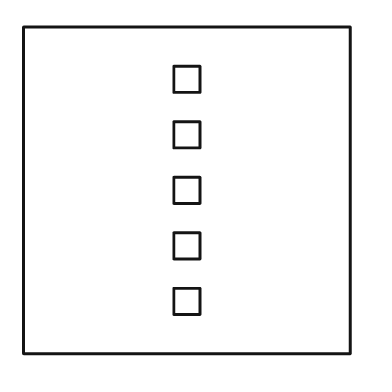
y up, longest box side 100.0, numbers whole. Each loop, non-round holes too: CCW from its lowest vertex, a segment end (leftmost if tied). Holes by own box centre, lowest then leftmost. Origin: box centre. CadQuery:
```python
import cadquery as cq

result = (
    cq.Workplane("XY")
    .moveTo(-50.0, -50.0)
    .lineTo(50.0, -50.0)
    .lineTo(50.0, 50.0)
    .lineTo(-50.0, 50.0)
    .close()
    .moveTo(-4.0, -38.0)
    .lineTo(4.0, -38.0)
    .lineTo(4.0, -30.0)
    .lineTo(-4.0, -30.0)
    .close()
    .moveTo(-4.0, -21.0)
    .lineTo(4.0, -21.0)
    .lineTo(4.0, -13.0)
    .lineTo(-4.0, -13.0)
    .close()
    .moveTo(-4.0, -4.0)
    .lineTo(4.0, -4.0)
    .lineTo(4.0, 4.0)
    .lineTo(-4.0, 4.0)
    .close()
    .moveTo(-4.0, 13.0)
    .lineTo(4.0, 13.0)
    .lineTo(4.0, 21.0)
    .lineTo(-4.0, 21.0)
    .close()
    .moveTo(-4.0, 30.0)
    .lineTo(4.0, 30.0)
    .lineTo(4.0, 38.0)
    .lineTo(-4.0, 38.0)
    .close()
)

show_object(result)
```